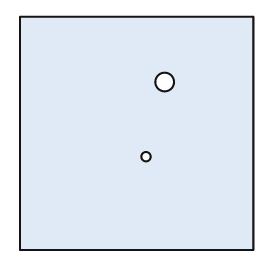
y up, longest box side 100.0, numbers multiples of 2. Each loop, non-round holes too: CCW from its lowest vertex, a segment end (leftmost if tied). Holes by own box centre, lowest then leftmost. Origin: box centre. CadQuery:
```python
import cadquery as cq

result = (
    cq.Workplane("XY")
    .moveTo(-50.0, -50.0)
    .lineTo(50.0, -50.0)
    .lineTo(50.0, 50.0)
    .lineTo(-50.0, 50.0)
    .close()
    .moveTo(4.0, -10.0)
    .circle(2.0)
    .moveTo(12.0, 22.0)
    .circle(4.0)
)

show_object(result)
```